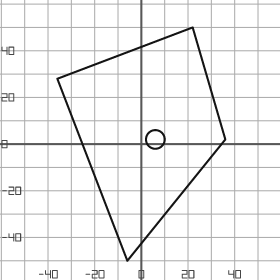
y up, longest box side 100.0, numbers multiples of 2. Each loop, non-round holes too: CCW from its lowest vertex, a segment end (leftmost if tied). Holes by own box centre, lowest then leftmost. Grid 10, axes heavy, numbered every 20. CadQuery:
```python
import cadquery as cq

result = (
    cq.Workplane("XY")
    .moveTo(-6.0, -50.0)
    .lineTo(36.0, 2.0)
    .lineTo(22.0, 50.0)
    .lineTo(-36.0, 28.0)
    .close()
    .moveTo(6.0, 2.0)
    .circle(4.0)
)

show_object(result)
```